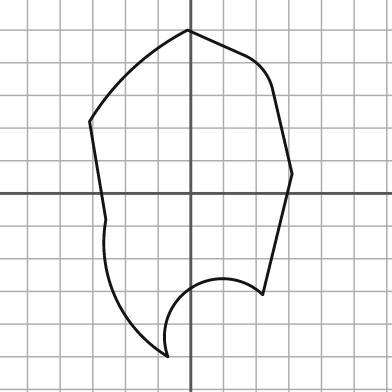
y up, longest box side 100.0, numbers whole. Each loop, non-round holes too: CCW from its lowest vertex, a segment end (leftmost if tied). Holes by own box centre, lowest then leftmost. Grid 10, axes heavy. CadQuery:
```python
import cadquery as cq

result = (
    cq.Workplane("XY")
    .moveTo(-7.0, -50.0)
    .threePointArc((0.0, -29.0), (22.0, -31.0))
    .lineTo(31.0, 6.0)
    .lineTo(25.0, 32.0)
    .threePointArc((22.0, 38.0), (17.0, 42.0))
    .lineTo(-1.0, 50.0)
    .threePointArc((-18.0, 38.0), (-31.0, 22.0))
    .lineTo(-26.0, -8.0)
    .threePointArc((-23.0, -32.0), (-7.0, -50.0))
    .close()
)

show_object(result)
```